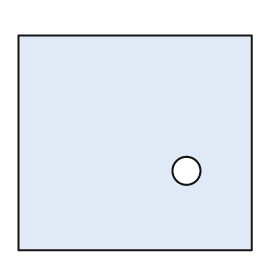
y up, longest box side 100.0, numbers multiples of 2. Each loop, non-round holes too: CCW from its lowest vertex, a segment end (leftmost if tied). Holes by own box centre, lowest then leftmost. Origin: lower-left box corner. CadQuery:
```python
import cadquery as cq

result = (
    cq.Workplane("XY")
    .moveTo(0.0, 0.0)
    .lineTo(100.0, 0.0)
    .lineTo(100.0, 92.0)
    .lineTo(0.0, 92.0)
    .close()
    .moveTo(72.0, 34.0)
    .circle(6.0)
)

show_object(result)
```